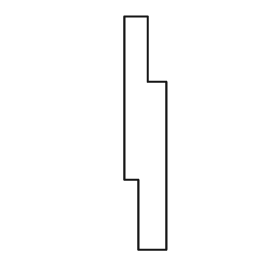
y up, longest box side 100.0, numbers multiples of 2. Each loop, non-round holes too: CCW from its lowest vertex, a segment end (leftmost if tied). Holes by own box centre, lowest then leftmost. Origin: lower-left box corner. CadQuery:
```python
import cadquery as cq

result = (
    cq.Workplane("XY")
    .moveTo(6.0, 0.0)
    .lineTo(18.0, 0.0)
    .lineTo(18.0, 72.0)
    .lineTo(10.0, 72.0)
    .lineTo(10.0, 100.0)
    .lineTo(0.0, 100.0)
    .lineTo(0.0, 30.0)
    .lineTo(6.0, 30.0)
    .close()
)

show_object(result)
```